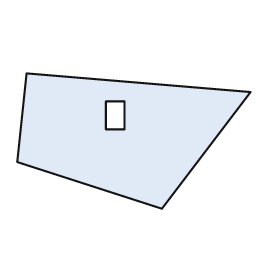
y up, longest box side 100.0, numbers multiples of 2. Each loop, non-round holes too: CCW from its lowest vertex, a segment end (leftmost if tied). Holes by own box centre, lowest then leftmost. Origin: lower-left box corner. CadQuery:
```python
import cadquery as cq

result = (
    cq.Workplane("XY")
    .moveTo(62.0, 0.0)
    .lineTo(100.0, 50.0)
    .lineTo(4.0, 58.0)
    .lineTo(0.0, 20.0)
    .close()
    .moveTo(38.0, 34.0)
    .lineTo(46.0, 34.0)
    .lineTo(46.0, 46.0)
    .lineTo(38.0, 46.0)
    .close()
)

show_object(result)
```